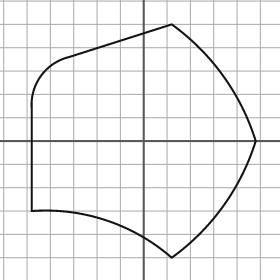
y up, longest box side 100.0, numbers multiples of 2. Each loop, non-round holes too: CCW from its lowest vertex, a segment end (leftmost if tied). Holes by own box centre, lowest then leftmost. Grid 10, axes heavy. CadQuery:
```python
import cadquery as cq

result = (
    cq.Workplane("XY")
    .moveTo(12.0, -50.0)
    .threePointArc((34.0, -28.0), (48.0, 0.0))
    .threePointArc((34.0, 28.0), (12.0, 50.0))
    .lineTo(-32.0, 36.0)
    .threePointArc((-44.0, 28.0), (-48.0, 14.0))
    .lineTo(-48.0, -30.0)
    .threePointArc((-16.0, -34.0), (12.0, -50.0))
    .close()
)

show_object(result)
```